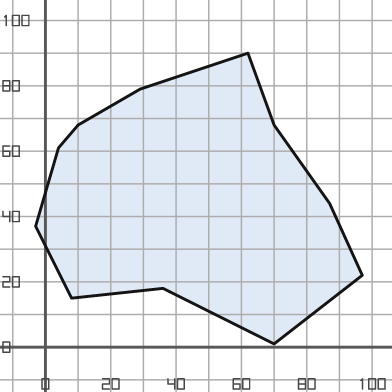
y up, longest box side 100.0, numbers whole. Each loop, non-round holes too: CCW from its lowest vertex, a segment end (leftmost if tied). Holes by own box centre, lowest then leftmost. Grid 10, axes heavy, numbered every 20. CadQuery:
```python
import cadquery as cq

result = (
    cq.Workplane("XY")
    .moveTo(70.0, 1.0)
    .lineTo(97.0, 22.0)
    .lineTo(87.0, 44.0)
    .lineTo(70.0, 68.0)
    .lineTo(62.0, 90.0)
    .lineTo(29.0, 79.0)
    .lineTo(10.0, 68.0)
    .lineTo(4.0, 61.0)
    .lineTo(-3.0, 37.0)
    .lineTo(8.0, 15.0)
    .lineTo(36.0, 18.0)
    .close()
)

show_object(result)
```